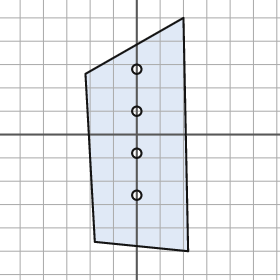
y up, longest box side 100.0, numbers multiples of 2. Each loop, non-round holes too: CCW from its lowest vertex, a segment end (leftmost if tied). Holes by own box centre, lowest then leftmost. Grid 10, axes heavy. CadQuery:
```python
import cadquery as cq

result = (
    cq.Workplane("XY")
    .moveTo(22.0, -50.0)
    .lineTo(20.0, 50.0)
    .lineTo(-22.0, 26.0)
    .lineTo(-18.0, -46.0)
    .close()
    .moveTo(0.0, -26.0)
    .circle(2.0)
    .moveTo(0.0, -8.0)
    .circle(2.0)
    .moveTo(0.0, 10.0)
    .circle(2.0)
    .moveTo(0.0, 28.0)
    .circle(2.0)
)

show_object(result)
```